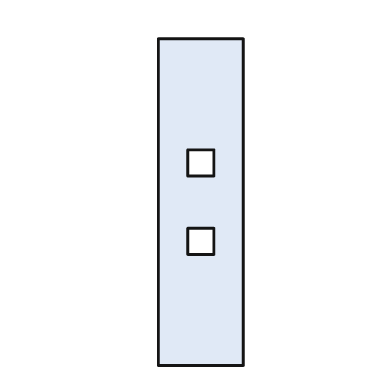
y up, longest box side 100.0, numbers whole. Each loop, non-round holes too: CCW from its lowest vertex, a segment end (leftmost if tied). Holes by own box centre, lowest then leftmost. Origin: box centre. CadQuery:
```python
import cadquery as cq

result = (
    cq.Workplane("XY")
    .moveTo(-13.0, -50.0)
    .lineTo(13.0, -50.0)
    .lineTo(13.0, 50.0)
    .lineTo(-13.0, 50.0)
    .close()
    .moveTo(-4.0, -16.0)
    .lineTo(4.0, -16.0)
    .lineTo(4.0, -8.0)
    .lineTo(-4.0, -8.0)
    .close()
    .moveTo(-4.0, 8.0)
    .lineTo(4.0, 8.0)
    .lineTo(4.0, 16.0)
    .lineTo(-4.0, 16.0)
    .close()
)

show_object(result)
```